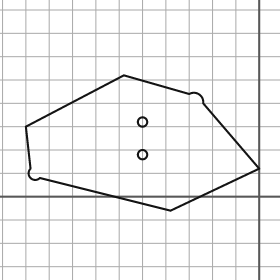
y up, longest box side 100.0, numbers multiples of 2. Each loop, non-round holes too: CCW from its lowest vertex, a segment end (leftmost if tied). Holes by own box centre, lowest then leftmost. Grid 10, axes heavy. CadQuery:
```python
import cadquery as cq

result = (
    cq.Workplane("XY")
    .moveTo(-38.0, -6.0)
    .lineTo(0.0, 12.0)
    .lineTo(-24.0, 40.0)
    .threePointArc((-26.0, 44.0), (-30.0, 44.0))
    .lineTo(-58.0, 52.0)
    .lineTo(-100.0, 30.0)
    .lineTo(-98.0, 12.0)
    .threePointArc((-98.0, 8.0), (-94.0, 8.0))
    .close()
    .moveTo(-50.0, 18.0)
    .circle(2.0)
    .moveTo(-50.0, 32.0)
    .circle(2.0)
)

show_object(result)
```